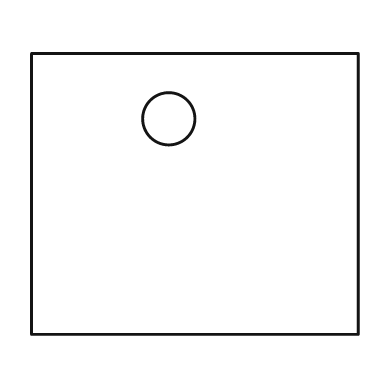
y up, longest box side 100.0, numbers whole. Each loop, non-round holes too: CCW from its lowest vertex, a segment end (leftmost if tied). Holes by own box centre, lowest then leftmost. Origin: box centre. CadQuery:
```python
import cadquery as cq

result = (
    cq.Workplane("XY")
    .moveTo(-50.0, -43.0)
    .lineTo(50.0, -43.0)
    .lineTo(50.0, 43.0)
    .lineTo(-50.0, 43.0)
    .close()
    .moveTo(-8.0, 23.0)
    .circle(8.0)
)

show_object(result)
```